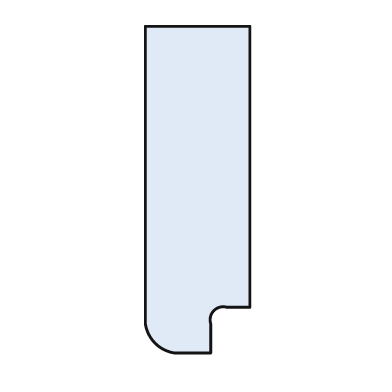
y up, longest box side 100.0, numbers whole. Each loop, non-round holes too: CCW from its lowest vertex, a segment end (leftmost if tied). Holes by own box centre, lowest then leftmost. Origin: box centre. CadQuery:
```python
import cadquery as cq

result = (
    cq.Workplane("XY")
    .moveTo(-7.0, -50.0)
    .lineTo(4.0, -50.0)
    .lineTo(4.0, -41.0)
    .threePointArc((5.0, -37.0), (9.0, -36.0))
    .lineTo(16.0, -36.0)
    .lineTo(16.0, 50.0)
    .lineTo(-16.0, 50.0)
    .lineTo(-16.0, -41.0)
    .threePointArc((-13.0, -47.0), (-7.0, -50.0))
    .close()
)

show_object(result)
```